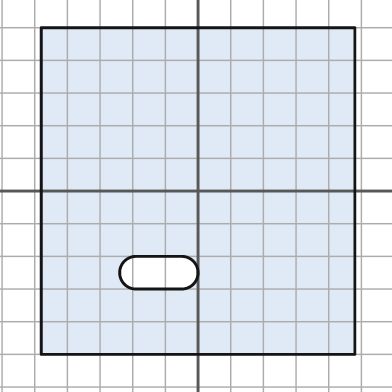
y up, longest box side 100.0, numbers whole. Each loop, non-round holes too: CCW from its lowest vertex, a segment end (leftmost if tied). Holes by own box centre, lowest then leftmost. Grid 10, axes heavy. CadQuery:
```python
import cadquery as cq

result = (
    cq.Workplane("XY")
    .moveTo(-48.0, -50.0)
    .lineTo(48.0, -50.0)
    .lineTo(48.0, 50.0)
    .lineTo(-48.0, 50.0)
    .close()
    .moveTo(-19.0, -30.0)
    .lineTo(-5.0, -30.0)
    .threePointArc((0.0, -25.0), (-5.0, -20.0))
    .lineTo(-19.0, -20.0)
    .threePointArc((-24.0, -25.0), (-19.0, -30.0))
    .close()
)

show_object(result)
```